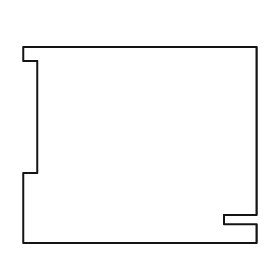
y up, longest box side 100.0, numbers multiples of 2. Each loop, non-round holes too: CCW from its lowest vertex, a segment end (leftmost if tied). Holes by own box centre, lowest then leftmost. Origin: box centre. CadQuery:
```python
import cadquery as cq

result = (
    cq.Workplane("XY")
    .moveTo(-50.0, -42.0)
    .lineTo(50.0, -42.0)
    .lineTo(50.0, -34.0)
    .lineTo(36.0, -34.0)
    .lineTo(36.0, -30.0)
    .lineTo(50.0, -30.0)
    .lineTo(50.0, 42.0)
    .lineTo(-50.0, 42.0)
    .lineTo(-50.0, 36.0)
    .lineTo(-44.0, 36.0)
    .lineTo(-44.0, -12.0)
    .lineTo(-50.0, -12.0)
    .close()
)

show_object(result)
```